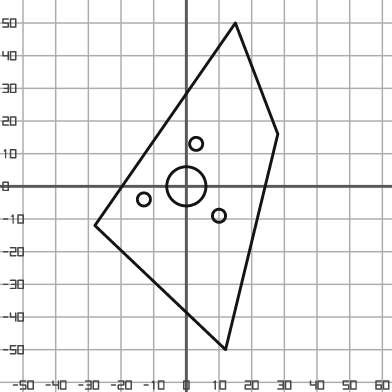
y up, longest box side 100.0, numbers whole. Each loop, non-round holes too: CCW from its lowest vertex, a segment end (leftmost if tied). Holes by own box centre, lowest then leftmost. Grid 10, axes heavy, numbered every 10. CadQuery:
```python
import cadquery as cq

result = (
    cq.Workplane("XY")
    .moveTo(12.0, -50.0)
    .lineTo(28.0, 16.0)
    .lineTo(15.0, 50.0)
    .lineTo(-28.0, -12.0)
    .close()
    .moveTo(10.0, -9.0)
    .circle(2.0)
    .moveTo(-13.0, -4.0)
    .circle(2.0)
    .moveTo(0.0, 0.0)
    .circle(6.0)
    .moveTo(3.0, 13.0)
    .circle(2.0)
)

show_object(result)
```